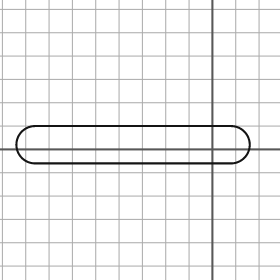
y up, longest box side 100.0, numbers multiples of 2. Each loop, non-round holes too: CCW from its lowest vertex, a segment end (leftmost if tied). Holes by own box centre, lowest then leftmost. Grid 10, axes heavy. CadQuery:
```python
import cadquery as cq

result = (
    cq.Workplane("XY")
    .moveTo(-76.0, -6.0)
    .lineTo(8.0, -6.0)
    .threePointArc((16.0, 2.0), (8.0, 10.0))
    .lineTo(-76.0, 10.0)
    .threePointArc((-84.0, 2.0), (-76.0, -6.0))
    .close()
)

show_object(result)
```